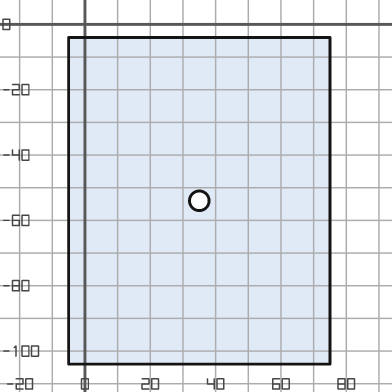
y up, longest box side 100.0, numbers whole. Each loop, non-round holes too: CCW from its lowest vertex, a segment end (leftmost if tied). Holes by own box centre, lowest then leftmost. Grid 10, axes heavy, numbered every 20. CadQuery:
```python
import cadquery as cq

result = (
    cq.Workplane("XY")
    .moveTo(-5.0, -104.0)
    .lineTo(75.0, -104.0)
    .lineTo(75.0, -4.0)
    .lineTo(-5.0, -4.0)
    .close()
    .moveTo(35.0, -54.0)
    .circle(3.0)
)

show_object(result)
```